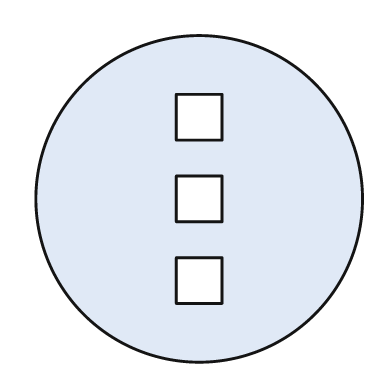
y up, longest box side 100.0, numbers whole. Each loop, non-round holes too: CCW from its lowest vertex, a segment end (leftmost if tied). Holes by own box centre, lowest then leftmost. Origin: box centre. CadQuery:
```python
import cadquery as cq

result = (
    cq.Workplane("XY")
    .moveTo(0.0, 0.0)
    .circle(50.0)
    .moveTo(-7.0, -32.0)
    .lineTo(7.0, -32.0)
    .lineTo(7.0, -18.0)
    .lineTo(-7.0, -18.0)
    .close()
    .moveTo(-7.0, -7.0)
    .lineTo(7.0, -7.0)
    .lineTo(7.0, 7.0)
    .lineTo(-7.0, 7.0)
    .close()
    .moveTo(-7.0, 18.0)
    .lineTo(7.0, 18.0)
    .lineTo(7.0, 32.0)
    .lineTo(-7.0, 32.0)
    .close()
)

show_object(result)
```